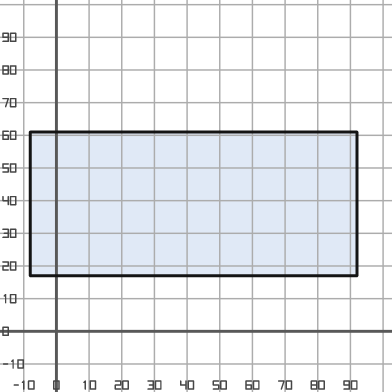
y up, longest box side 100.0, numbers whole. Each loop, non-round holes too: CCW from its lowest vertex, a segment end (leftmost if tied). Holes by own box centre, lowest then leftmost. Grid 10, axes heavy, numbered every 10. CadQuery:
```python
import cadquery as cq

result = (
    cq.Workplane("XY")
    .moveTo(-8.0, 17.0)
    .lineTo(92.0, 17.0)
    .lineTo(92.0, 61.0)
    .lineTo(-8.0, 61.0)
    .close()
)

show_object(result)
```